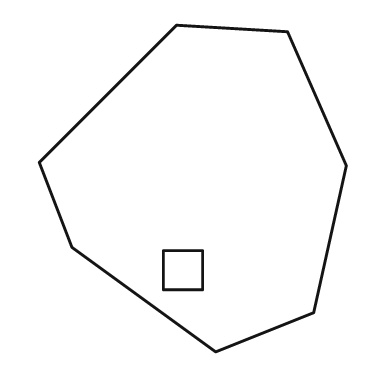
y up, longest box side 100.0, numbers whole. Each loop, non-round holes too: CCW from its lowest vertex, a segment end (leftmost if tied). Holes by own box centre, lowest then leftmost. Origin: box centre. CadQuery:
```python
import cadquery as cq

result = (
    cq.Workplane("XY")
    .moveTo(7.0, -50.0)
    .lineTo(37.0, -38.0)
    .lineTo(47.0, 7.0)
    .lineTo(29.0, 48.0)
    .lineTo(-5.0, 50.0)
    .lineTo(-47.0, 8.0)
    .lineTo(-37.0, -18.0)
    .close()
    .moveTo(-9.0, -31.0)
    .lineTo(3.0, -31.0)
    .lineTo(3.0, -19.0)
    .lineTo(-9.0, -19.0)
    .close()
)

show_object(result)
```